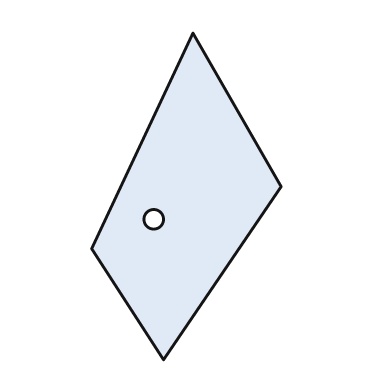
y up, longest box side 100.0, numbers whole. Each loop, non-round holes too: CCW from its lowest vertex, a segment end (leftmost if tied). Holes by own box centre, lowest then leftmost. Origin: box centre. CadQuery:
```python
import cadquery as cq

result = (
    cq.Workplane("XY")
    .moveTo(-7.0, -50.0)
    .lineTo(29.0, 3.0)
    .lineTo(2.0, 50.0)
    .lineTo(-29.0, -16.0)
    .close()
    .moveTo(-10.0, -7.0)
    .circle(3.0)
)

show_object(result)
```